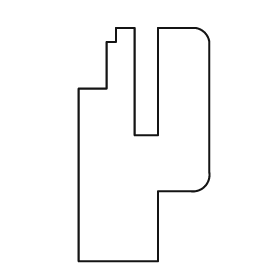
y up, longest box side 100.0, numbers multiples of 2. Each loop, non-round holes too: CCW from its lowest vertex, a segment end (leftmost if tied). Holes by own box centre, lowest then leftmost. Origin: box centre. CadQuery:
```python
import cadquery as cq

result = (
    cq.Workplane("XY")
    .moveTo(-28.0, -50.0)
    .lineTo(6.0, -50.0)
    .lineTo(6.0, -20.0)
    .lineTo(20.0, -20.0)
    .threePointArc((26.0, -18.0), (28.0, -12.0))
    .lineTo(28.0, 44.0)
    .threePointArc((26.0, 48.0), (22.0, 50.0))
    .lineTo(6.0, 50.0)
    .lineTo(6.0, 4.0)
    .lineTo(-4.0, 4.0)
    .lineTo(-4.0, 50.0)
    .lineTo(-12.0, 50.0)
    .lineTo(-12.0, 44.0)
    .lineTo(-16.0, 44.0)
    .lineTo(-16.0, 24.0)
    .lineTo(-28.0, 24.0)
    .close()
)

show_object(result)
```